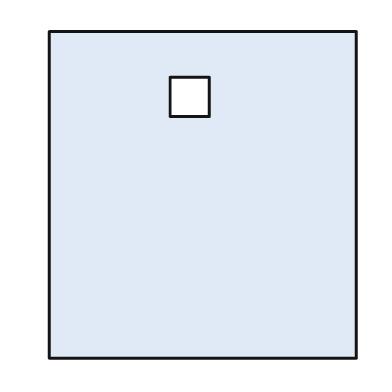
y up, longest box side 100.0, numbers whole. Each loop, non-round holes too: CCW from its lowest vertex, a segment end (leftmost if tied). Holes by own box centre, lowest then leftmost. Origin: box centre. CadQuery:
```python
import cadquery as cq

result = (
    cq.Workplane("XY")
    .moveTo(-47.0, -50.0)
    .lineTo(47.0, -50.0)
    .lineTo(47.0, 50.0)
    .lineTo(-47.0, 50.0)
    .close()
    .moveTo(-10.0, 24.0)
    .lineTo(2.0, 24.0)
    .lineTo(2.0, 36.0)
    .lineTo(-10.0, 36.0)
    .close()
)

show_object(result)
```